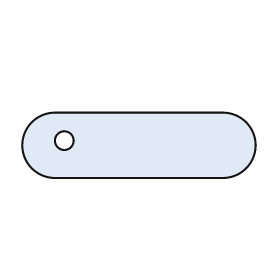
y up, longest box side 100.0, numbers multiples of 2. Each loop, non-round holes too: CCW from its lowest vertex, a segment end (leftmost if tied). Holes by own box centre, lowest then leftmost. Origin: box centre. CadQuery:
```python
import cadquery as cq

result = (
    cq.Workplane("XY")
    .moveTo(-36.0, -14.0)
    .lineTo(36.0, -14.0)
    .threePointArc((50.0, 0.0), (36.0, 14.0))
    .lineTo(-36.0, 14.0)
    .threePointArc((-50.0, 0.0), (-36.0, -14.0))
    .close()
    .moveTo(-32.0, 2.0)
    .circle(4.0)
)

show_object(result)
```